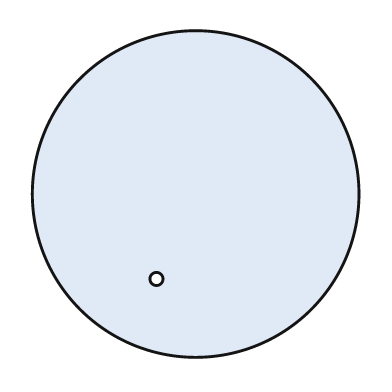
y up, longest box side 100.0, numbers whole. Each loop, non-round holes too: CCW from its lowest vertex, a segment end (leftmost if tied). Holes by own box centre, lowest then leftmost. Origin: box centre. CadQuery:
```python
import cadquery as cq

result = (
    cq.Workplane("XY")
    .moveTo(0.0, 0.0)
    .circle(50.0)
    .moveTo(-12.0, -26.0)
    .circle(2.0)
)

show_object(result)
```